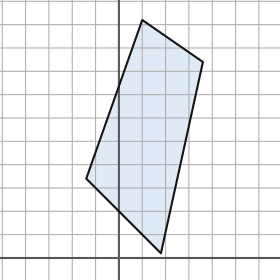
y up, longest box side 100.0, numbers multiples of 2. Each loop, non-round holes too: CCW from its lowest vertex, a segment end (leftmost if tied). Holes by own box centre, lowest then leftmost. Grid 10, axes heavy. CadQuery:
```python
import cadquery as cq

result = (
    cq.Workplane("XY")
    .moveTo(18.0, 2.0)
    .lineTo(36.0, 84.0)
    .lineTo(10.0, 102.0)
    .lineTo(-14.0, 34.0)
    .close()
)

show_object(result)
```